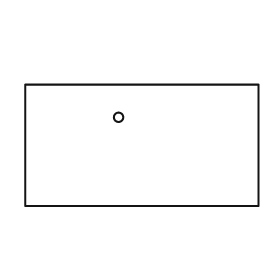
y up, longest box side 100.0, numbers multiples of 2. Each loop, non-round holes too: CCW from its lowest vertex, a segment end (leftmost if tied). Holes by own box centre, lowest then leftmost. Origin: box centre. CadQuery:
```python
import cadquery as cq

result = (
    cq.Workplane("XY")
    .moveTo(-50.0, -26.0)
    .lineTo(50.0, -26.0)
    .lineTo(50.0, 26.0)
    .lineTo(-50.0, 26.0)
    .close()
    .moveTo(-10.0, 12.0)
    .circle(2.0)
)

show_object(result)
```